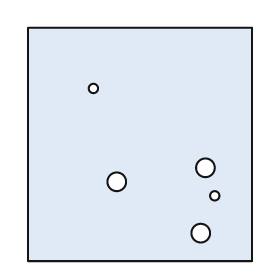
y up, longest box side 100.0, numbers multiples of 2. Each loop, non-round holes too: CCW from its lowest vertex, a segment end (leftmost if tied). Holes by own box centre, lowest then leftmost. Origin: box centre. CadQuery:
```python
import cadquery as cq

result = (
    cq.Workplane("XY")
    .moveTo(-48.0, -50.0)
    .lineTo(48.0, -50.0)
    .lineTo(48.0, 50.0)
    .lineTo(-48.0, 50.0)
    .close()
    .moveTo(26.0, -38.0)
    .circle(4.0)
    .moveTo(32.0, -22.0)
    .circle(2.0)
    .moveTo(-10.0, -16.0)
    .circle(4.0)
    .moveTo(28.0, -10.0)
    .circle(4.0)
    .moveTo(-20.0, 24.0)
    .circle(2.0)
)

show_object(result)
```